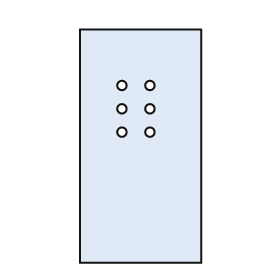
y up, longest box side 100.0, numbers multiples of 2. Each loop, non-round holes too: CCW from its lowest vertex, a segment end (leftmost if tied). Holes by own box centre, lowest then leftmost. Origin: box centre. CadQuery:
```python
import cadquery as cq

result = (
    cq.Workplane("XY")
    .moveTo(-26.0, -50.0)
    .lineTo(26.0, -50.0)
    .lineTo(26.0, 50.0)
    .lineTo(-26.0, 50.0)
    .close()
    .moveTo(-8.0, 6.0)
    .circle(2.0)
    .moveTo(4.0, 6.0)
    .circle(2.0)
    .moveTo(-8.0, 16.0)
    .circle(2.0)
    .moveTo(4.0, 16.0)
    .circle(2.0)
    .moveTo(-8.0, 26.0)
    .circle(2.0)
    .moveTo(4.0, 26.0)
    .circle(2.0)
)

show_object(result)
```